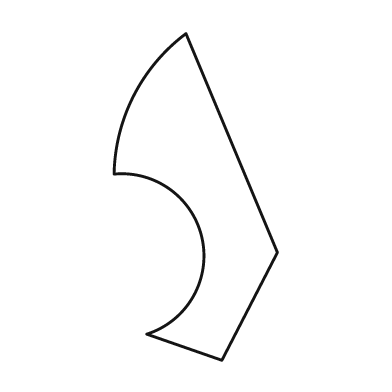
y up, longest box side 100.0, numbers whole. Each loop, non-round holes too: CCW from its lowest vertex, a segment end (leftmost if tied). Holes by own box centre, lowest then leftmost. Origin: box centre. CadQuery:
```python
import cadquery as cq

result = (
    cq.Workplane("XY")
    .moveTo(8.0, -50.0)
    .lineTo(25.0, -17.0)
    .lineTo(-3.0, 50.0)
    .threePointArc((-19.0, 31.0), (-25.0, 7.0))
    .threePointArc((2.0, -13.0), (-15.0, -42.0))
    .close()
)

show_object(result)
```